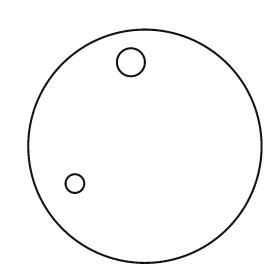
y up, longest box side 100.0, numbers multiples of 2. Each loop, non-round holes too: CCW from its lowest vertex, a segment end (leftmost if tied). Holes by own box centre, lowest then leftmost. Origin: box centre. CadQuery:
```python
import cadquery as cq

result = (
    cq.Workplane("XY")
    .moveTo(0.0, 0.0)
    .circle(50.0)
    .moveTo(-30.0, -16.0)
    .circle(4.0)
    .moveTo(-6.0, 36.0)
    .circle(6.0)
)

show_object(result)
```